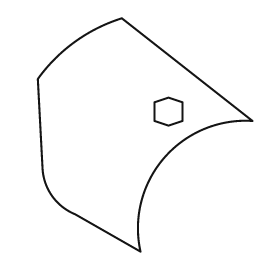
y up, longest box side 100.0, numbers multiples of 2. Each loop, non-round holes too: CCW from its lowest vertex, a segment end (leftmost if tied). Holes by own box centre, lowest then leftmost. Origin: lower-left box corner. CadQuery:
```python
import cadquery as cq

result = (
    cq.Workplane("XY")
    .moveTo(44.0, 0.0)
    .threePointArc((54.0, 40.0), (92.0, 56.0))
    .lineTo(36.0, 100.0)
    .threePointArc((16.0, 90.0), (0.0, 74.0))
    .lineTo(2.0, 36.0)
    .threePointArc((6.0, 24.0), (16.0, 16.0))
    .close()
    .moveTo(56.0, 54.0)
    .lineTo(62.0, 56.0)
    .lineTo(62.0, 64.0)
    .lineTo(56.0, 66.0)
    .lineTo(50.0, 64.0)
    .lineTo(50.0, 56.0)
    .close()
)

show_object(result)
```